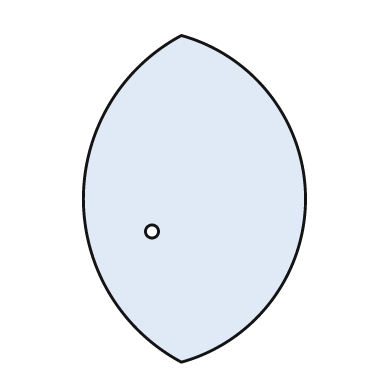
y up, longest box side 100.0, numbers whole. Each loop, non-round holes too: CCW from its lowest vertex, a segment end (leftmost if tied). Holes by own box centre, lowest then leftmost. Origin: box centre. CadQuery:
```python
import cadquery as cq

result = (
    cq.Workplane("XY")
    .moveTo(-4.0, -50.0)
    .threePointArc((34.0, 0.0), (-4.0, 50.0))
    .threePointArc((-34.0, 0.0), (-4.0, -50.0))
    .close()
    .moveTo(-13.0, -10.0)
    .circle(2.0)
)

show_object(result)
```